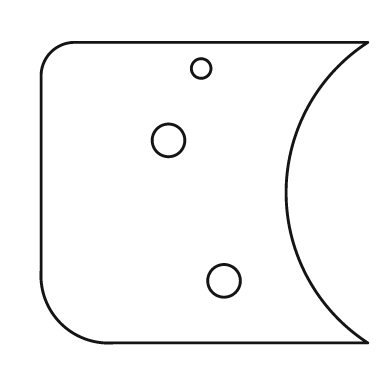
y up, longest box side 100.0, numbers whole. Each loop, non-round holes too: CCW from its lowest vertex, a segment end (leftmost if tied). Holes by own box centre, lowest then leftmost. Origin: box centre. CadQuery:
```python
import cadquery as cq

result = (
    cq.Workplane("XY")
    .moveTo(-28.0, -46.0)
    .lineTo(50.0, -46.0)
    .threePointArc((25.0, 0.0), (50.0, 46.0))
    .lineTo(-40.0, 46.0)
    .threePointArc((-47.0, 43.0), (-50.0, 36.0))
    .lineTo(-50.0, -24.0)
    .threePointArc((-44.0, -40.0), (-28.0, -46.0))
    .close()
    .moveTo(6.0, -27.0)
    .circle(5.0)
    .moveTo(-11.0, 16.0)
    .circle(5.0)
    .moveTo(-1.0, 38.0)
    .circle(3.0)
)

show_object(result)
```